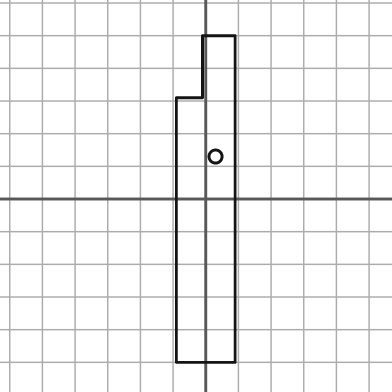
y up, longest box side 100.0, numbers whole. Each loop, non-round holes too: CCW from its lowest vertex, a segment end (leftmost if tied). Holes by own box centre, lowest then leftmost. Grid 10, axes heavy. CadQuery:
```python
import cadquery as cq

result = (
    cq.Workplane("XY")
    .moveTo(-9.0, -50.0)
    .lineTo(9.0, -50.0)
    .lineTo(9.0, 50.0)
    .lineTo(-1.0, 50.0)
    .lineTo(-1.0, 31.0)
    .lineTo(-9.0, 31.0)
    .close()
    .moveTo(3.0, 13.0)
    .circle(2.0)
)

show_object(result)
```